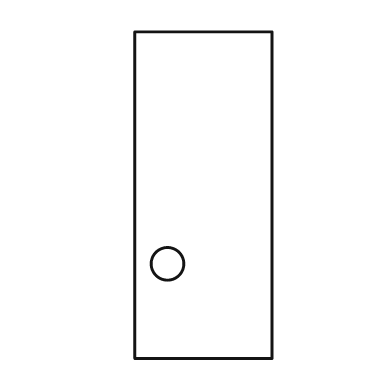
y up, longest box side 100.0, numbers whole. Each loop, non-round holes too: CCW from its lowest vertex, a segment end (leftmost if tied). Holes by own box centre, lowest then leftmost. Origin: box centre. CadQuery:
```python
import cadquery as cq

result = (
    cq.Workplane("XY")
    .moveTo(-21.0, -50.0)
    .lineTo(21.0, -50.0)
    .lineTo(21.0, 50.0)
    .lineTo(-21.0, 50.0)
    .close()
    .moveTo(-11.0, -21.0)
    .circle(5.0)
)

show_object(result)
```